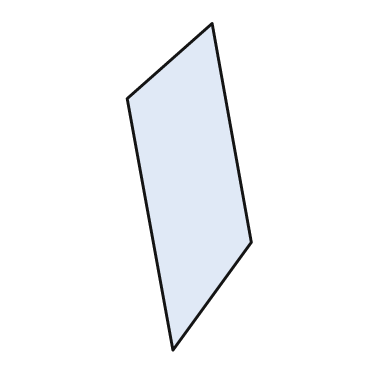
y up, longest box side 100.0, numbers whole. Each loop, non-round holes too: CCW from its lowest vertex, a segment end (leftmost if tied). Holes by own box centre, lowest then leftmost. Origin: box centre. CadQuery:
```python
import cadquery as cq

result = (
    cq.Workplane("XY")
    .moveTo(-5.0, -50.0)
    .lineTo(19.0, -17.0)
    .lineTo(7.0, 50.0)
    .lineTo(-19.0, 27.0)
    .close()
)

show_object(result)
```